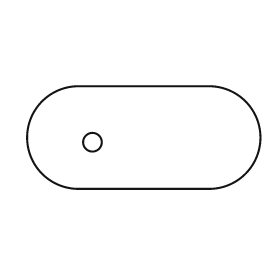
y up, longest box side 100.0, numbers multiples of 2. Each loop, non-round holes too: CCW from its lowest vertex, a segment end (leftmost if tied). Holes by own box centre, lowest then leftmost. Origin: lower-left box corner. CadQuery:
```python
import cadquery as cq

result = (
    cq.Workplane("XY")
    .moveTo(22.0, 0.0)
    .lineTo(78.0, 0.0)
    .threePointArc((100.0, 22.0), (78.0, 44.0))
    .lineTo(22.0, 44.0)
    .threePointArc((0.0, 22.0), (22.0, 0.0))
    .close()
    .moveTo(28.0, 20.0)
    .circle(4.0)
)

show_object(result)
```